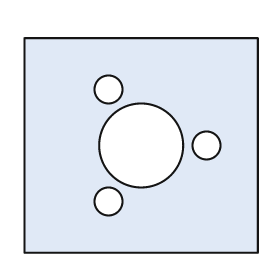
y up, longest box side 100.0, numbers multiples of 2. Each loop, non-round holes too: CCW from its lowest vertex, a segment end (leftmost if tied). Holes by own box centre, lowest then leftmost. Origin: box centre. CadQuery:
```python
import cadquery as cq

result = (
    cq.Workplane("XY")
    .moveTo(-50.0, -46.0)
    .lineTo(50.0, -46.0)
    .lineTo(50.0, 46.0)
    .lineTo(-50.0, 46.0)
    .close()
    .moveTo(-14.0, -24.0)
    .circle(6.0)
    .moveTo(0.0, 0.0)
    .circle(18.0)
    .moveTo(28.0, 0.0)
    .circle(6.0)
    .moveTo(-14.0, 24.0)
    .circle(6.0)
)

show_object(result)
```